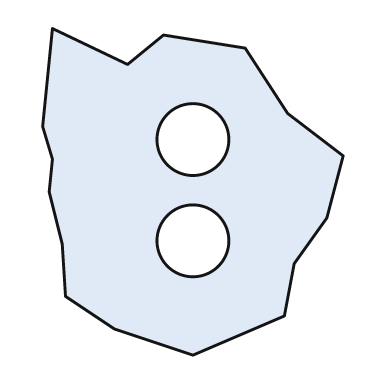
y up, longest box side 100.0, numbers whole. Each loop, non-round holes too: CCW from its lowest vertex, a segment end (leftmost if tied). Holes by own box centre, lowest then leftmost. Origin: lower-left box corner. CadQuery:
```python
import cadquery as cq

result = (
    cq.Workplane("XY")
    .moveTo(46.0, 0.0)
    .lineTo(74.0, 12.0)
    .lineTo(77.0, 28.0)
    .lineTo(87.0, 42.0)
    .lineTo(92.0, 61.0)
    .lineTo(75.0, 74.0)
    .lineTo(62.0, 94.0)
    .lineTo(37.0, 98.0)
    .lineTo(26.0, 89.0)
    .lineTo(3.0, 100.0)
    .lineTo(0.0, 70.0)
    .lineTo(3.0, 60.0)
    .lineTo(2.0, 50.0)
    .lineTo(6.0, 34.0)
    .lineTo(7.0, 18.0)
    .lineTo(22.0, 8.0)
    .close()
    .moveTo(46.0, 35.0)
    .circle(11.0)
    .moveTo(46.0, 66.0)
    .circle(11.0)
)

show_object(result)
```